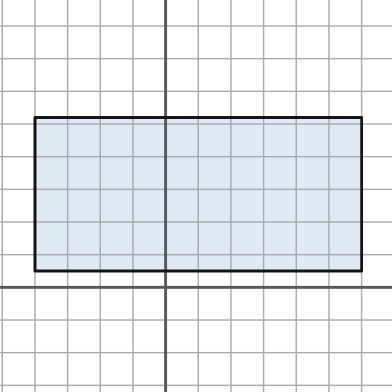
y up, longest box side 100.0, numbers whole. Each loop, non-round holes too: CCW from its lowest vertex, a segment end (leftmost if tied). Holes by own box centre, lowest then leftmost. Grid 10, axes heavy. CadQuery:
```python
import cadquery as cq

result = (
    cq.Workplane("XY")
    .moveTo(-40.0, 5.0)
    .lineTo(60.0, 5.0)
    .lineTo(60.0, 52.0)
    .lineTo(-40.0, 52.0)
    .close()
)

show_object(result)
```